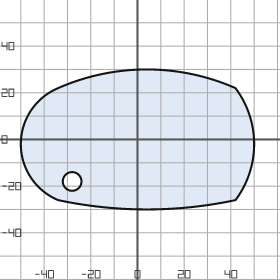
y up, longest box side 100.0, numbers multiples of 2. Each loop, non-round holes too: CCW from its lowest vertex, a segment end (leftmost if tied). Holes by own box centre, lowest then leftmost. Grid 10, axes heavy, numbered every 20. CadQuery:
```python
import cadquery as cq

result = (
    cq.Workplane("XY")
    .moveTo(-34.0, -26.0)
    .threePointArc((4.0, -30.0), (42.0, -26.0))
    .threePointArc((50.0, -2.0), (42.0, 22.0))
    .threePointArc((4.0, 30.0), (-34.0, 22.0))
    .threePointArc((-50.0, -2.0), (-34.0, -26.0))
    .close()
    .moveTo(-28.0, -18.0)
    .circle(4.0)
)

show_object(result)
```